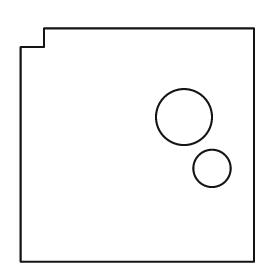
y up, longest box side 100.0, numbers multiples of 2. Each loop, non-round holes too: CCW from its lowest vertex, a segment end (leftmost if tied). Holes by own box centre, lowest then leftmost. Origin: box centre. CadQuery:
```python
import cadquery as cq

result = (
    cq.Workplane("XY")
    .moveTo(-50.0, -50.0)
    .lineTo(50.0, -50.0)
    .lineTo(50.0, 50.0)
    .lineTo(-40.0, 50.0)
    .lineTo(-40.0, 42.0)
    .lineTo(-50.0, 42.0)
    .close()
    .moveTo(32.0, -10.0)
    .circle(8.0)
    .moveTo(20.0, 12.0)
    .circle(12.0)
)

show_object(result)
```